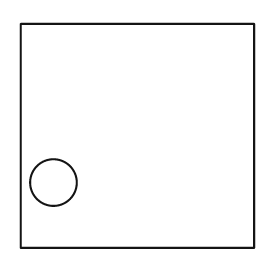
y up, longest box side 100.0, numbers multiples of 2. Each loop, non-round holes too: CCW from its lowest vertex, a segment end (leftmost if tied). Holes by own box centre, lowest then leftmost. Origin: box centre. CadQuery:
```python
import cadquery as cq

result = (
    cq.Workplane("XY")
    .moveTo(-50.0, -48.0)
    .lineTo(50.0, -48.0)
    .lineTo(50.0, 48.0)
    .lineTo(-50.0, 48.0)
    .close()
    .moveTo(-36.0, -20.0)
    .circle(10.0)
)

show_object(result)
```